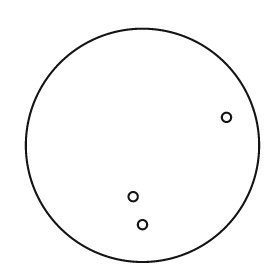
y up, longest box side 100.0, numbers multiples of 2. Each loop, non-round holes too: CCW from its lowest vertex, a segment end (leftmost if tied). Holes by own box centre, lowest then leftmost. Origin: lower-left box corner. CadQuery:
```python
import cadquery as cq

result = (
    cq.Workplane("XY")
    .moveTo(50.0, 50.0)
    .circle(50.0)
    .moveTo(50.0, 16.0)
    .circle(2.0)
    .moveTo(46.0, 28.0)
    .circle(2.0)
    .moveTo(86.0, 62.0)
    .circle(2.0)
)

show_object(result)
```